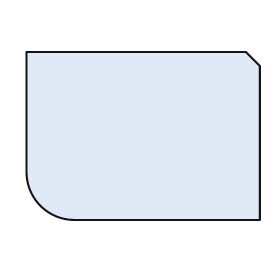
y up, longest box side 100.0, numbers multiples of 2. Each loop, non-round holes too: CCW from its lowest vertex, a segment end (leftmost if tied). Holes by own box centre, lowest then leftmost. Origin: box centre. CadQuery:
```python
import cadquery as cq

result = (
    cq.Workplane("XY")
    .moveTo(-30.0, -36.0)
    .lineTo(50.0, -36.0)
    .lineTo(50.0, 30.0)
    .lineTo(44.0, 36.0)
    .lineTo(-50.0, 36.0)
    .lineTo(-50.0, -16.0)
    .threePointArc((-44.0, -30.0), (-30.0, -36.0))
    .close()
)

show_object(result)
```